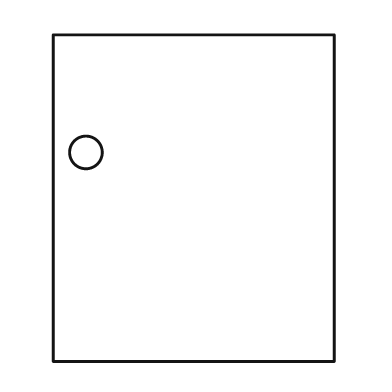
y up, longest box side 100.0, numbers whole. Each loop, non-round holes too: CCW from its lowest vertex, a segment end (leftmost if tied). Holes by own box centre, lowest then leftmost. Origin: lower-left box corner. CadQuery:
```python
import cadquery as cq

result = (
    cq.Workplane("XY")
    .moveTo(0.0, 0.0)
    .lineTo(86.0, 0.0)
    .lineTo(86.0, 100.0)
    .lineTo(0.0, 100.0)
    .close()
    .moveTo(10.0, 64.0)
    .circle(5.0)
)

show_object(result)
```